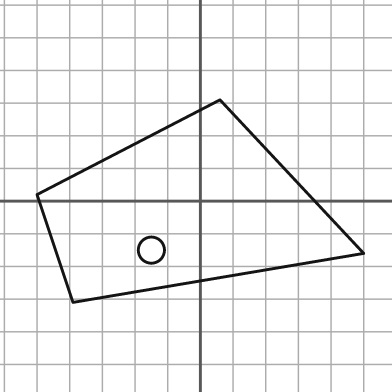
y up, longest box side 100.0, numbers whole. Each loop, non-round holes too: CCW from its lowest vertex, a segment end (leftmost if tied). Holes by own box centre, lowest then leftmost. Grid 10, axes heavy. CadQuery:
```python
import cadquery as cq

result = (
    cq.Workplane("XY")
    .moveTo(-39.0, -31.0)
    .lineTo(50.0, -16.0)
    .lineTo(6.0, 31.0)
    .lineTo(-50.0, 2.0)
    .close()
    .moveTo(-15.0, -15.0)
    .circle(4.0)
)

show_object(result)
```